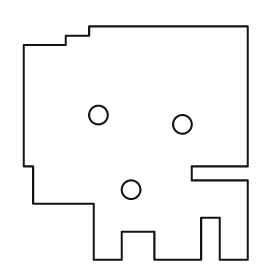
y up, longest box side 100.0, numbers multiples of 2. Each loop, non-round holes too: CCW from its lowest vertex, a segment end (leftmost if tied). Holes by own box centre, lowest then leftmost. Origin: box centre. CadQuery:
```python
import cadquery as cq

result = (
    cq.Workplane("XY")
    .moveTo(-18.0, -50.0)
    .lineTo(-6.0, -50.0)
    .lineTo(-6.0, -38.0)
    .lineTo(8.0, -38.0)
    .lineTo(8.0, -50.0)
    .lineTo(28.0, -50.0)
    .lineTo(28.0, -32.0)
    .lineTo(36.0, -32.0)
    .lineTo(36.0, -50.0)
    .lineTo(48.0, -50.0)
    .lineTo(48.0, -16.0)
    .lineTo(24.0, -16.0)
    .lineTo(24.0, -10.0)
    .lineTo(48.0, -10.0)
    .lineTo(48.0, 50.0)
    .lineTo(-20.0, 50.0)
    .lineTo(-20.0, 46.0)
    .lineTo(-30.0, 46.0)
    .lineTo(-30.0, 42.0)
    .lineTo(-48.0, 42.0)
    .lineTo(-48.0, -10.0)
    .lineTo(-44.0, -10.0)
    .lineTo(-44.0, -26.0)
    .lineTo(-18.0, -26.0)
    .close()
    .moveTo(-2.0, -20.0)
    .circle(4.0)
    .moveTo(20.0, 8.0)
    .circle(4.0)
    .moveTo(-16.0, 12.0)
    .circle(4.0)
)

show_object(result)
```